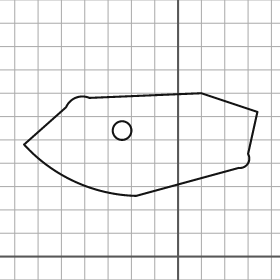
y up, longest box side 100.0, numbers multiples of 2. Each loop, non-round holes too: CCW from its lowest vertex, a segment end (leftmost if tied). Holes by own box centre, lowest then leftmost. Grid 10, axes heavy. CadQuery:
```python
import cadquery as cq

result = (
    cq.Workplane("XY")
    .moveTo(-18.0, 26.0)
    .lineTo(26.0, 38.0)
    .threePointArc((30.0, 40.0), (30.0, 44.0))
    .lineTo(34.0, 62.0)
    .lineTo(10.0, 70.0)
    .lineTo(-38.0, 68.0)
    .threePointArc((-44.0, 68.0), (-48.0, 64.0))
    .lineTo(-66.0, 48.0)
    .threePointArc((-44.0, 32.0), (-18.0, 26.0))
    .close()
    .moveTo(-24.0, 54.0)
    .circle(4.0)
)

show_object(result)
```